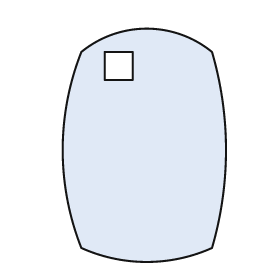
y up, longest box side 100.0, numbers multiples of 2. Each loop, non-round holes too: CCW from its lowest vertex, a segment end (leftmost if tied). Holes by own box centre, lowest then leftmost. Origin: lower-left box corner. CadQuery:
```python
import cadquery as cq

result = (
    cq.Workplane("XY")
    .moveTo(8.0, 6.0)
    .threePointArc((36.0, 0.0), (64.0, 6.0))
    .threePointArc((70.0, 48.0), (64.0, 90.0))
    .threePointArc((36.0, 100.0), (8.0, 90.0))
    .threePointArc((0.0, 48.0), (8.0, 6.0))
    .close()
    .moveTo(18.0, 78.0)
    .lineTo(30.0, 78.0)
    .lineTo(30.0, 90.0)
    .lineTo(18.0, 90.0)
    .close()
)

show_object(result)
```